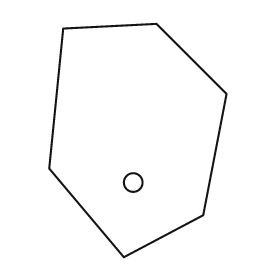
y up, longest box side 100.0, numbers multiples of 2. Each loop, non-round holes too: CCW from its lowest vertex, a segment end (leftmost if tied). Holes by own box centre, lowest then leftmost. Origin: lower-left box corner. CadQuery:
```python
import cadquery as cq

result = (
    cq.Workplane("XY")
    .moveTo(32.0, 0.0)
    .lineTo(66.0, 18.0)
    .lineTo(76.0, 70.0)
    .lineTo(46.0, 100.0)
    .lineTo(6.0, 98.0)
    .lineTo(0.0, 38.0)
    .close()
    .moveTo(36.0, 32.0)
    .circle(4.0)
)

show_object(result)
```